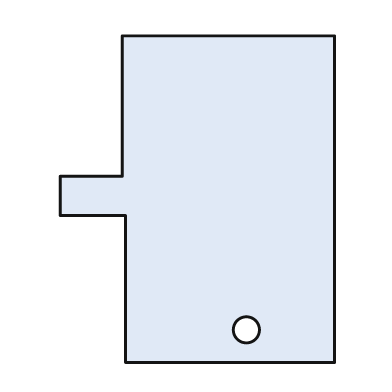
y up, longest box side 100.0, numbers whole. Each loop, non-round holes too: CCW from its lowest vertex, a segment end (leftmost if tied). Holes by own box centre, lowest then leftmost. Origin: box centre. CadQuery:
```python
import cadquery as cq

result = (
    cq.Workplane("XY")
    .moveTo(-22.0, -50.0)
    .lineTo(42.0, -50.0)
    .lineTo(42.0, 50.0)
    .lineTo(-23.0, 50.0)
    .lineTo(-23.0, 7.0)
    .lineTo(-42.0, 7.0)
    .lineTo(-42.0, -5.0)
    .lineTo(-22.0, -5.0)
    .close()
    .moveTo(15.0, -40.0)
    .circle(4.0)
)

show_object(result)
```